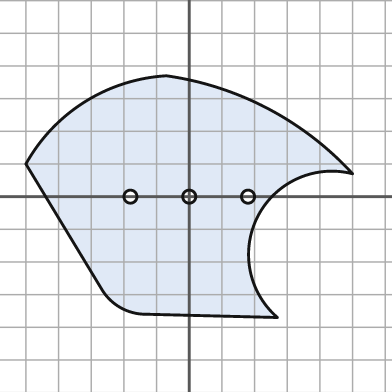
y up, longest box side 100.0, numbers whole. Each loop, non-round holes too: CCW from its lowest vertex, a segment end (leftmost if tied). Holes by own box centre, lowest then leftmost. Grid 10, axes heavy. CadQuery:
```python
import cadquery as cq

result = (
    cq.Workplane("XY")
    .moveTo(27.0, -37.0)
    .threePointArc((21.0, -6.0), (50.0, 7.0))
    .threePointArc((24.0, 27.0), (-7.0, 37.0))
    .threePointArc((-32.0, 29.0), (-50.0, 10.0))
    .lineTo(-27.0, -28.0)
    .threePointArc((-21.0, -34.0), (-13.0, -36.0))
    .close()
    .moveTo(-18.0, 0.0)
    .circle(2.0)
    .moveTo(0.0, 0.0)
    .circle(2.0)
    .moveTo(18.0, 0.0)
    .circle(2.0)
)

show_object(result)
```